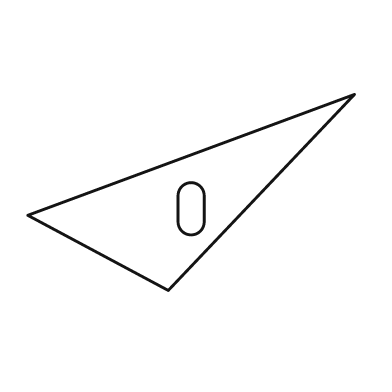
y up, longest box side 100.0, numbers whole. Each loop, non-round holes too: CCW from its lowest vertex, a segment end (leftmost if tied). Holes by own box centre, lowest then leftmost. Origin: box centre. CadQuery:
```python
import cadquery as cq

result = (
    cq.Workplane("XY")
    .moveTo(-7.0, -30.0)
    .lineTo(50.0, 30.0)
    .lineTo(-50.0, -7.0)
    .close()
    .moveTo(-4.0, -9.0)
    .threePointArc((0.0, -13.0), (4.0, -9.0))
    .lineTo(4.0, -1.0)
    .threePointArc((0.0, 3.0), (-4.0, -1.0))
    .close()
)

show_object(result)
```